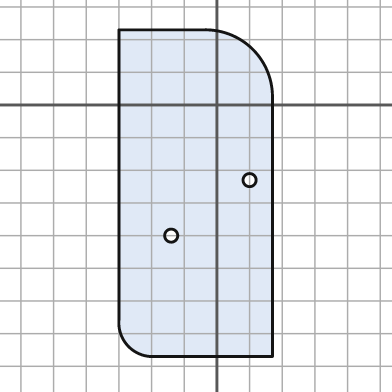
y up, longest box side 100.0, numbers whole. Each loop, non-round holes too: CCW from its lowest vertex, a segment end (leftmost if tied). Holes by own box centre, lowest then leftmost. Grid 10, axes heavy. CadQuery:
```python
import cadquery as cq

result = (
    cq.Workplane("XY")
    .moveTo(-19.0, -77.0)
    .lineTo(17.0, -77.0)
    .lineTo(17.0, 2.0)
    .threePointArc((11.0, 17.0), (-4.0, 23.0))
    .lineTo(-30.0, 23.0)
    .lineTo(-30.0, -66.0)
    .threePointArc((-27.0, -74.0), (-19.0, -77.0))
    .close()
    .moveTo(-14.0, -40.0)
    .circle(2.0)
    .moveTo(10.0, -23.0)
    .circle(2.0)
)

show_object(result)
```